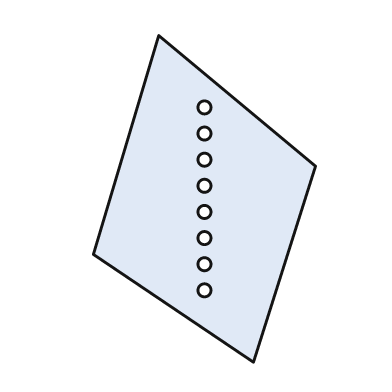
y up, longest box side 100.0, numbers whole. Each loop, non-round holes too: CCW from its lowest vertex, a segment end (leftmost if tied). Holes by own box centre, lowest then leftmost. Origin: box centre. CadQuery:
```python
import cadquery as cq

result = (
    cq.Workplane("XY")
    .moveTo(15.0, -50.0)
    .lineTo(34.0, 10.0)
    .lineTo(-14.0, 50.0)
    .lineTo(-34.0, -17.0)
    .close()
    .moveTo(0.0, -28.0)
    .circle(2.0)
    .moveTo(0.0, -20.0)
    .circle(2.0)
    .moveTo(0.0, -12.0)
    .circle(2.0)
    .moveTo(0.0, -4.0)
    .circle(2.0)
    .moveTo(0.0, 4.0)
    .circle(2.0)
    .moveTo(0.0, 12.0)
    .circle(2.0)
    .moveTo(0.0, 20.0)
    .circle(2.0)
    .moveTo(0.0, 28.0)
    .circle(2.0)
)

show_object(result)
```